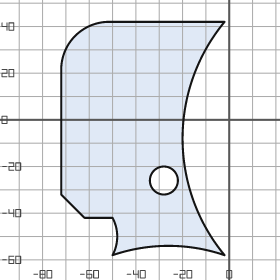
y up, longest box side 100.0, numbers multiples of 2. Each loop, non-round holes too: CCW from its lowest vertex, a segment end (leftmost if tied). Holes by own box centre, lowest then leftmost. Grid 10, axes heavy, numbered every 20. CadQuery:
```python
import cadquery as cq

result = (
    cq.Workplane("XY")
    .moveTo(-50.0, -58.0)
    .threePointArc((-26.0, -54.0), (-2.0, -58.0))
    .threePointArc((-20.0, -8.0), (-2.0, 42.0))
    .lineTo(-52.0, 42.0)
    .threePointArc((-66.0, 36.0), (-72.0, 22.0))
    .lineTo(-72.0, -32.0)
    .lineTo(-62.0, -42.0)
    .lineTo(-50.0, -42.0)
    .threePointArc((-48.0, -50.0), (-50.0, -58.0))
    .close()
    .moveTo(-28.0, -26.0)
    .circle(6.0)
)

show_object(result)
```